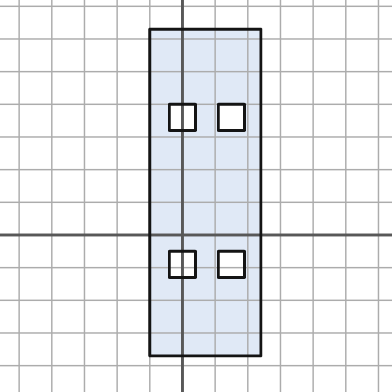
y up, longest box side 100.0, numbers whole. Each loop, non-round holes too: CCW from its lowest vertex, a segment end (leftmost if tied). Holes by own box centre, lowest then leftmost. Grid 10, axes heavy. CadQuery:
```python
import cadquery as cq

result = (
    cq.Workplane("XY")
    .moveTo(-10.0, -37.0)
    .lineTo(24.0, -37.0)
    .lineTo(24.0, 63.0)
    .lineTo(-10.0, 63.0)
    .close()
    .moveTo(-4.0, -13.0)
    .lineTo(4.0, -13.0)
    .lineTo(4.0, -5.0)
    .lineTo(-4.0, -5.0)
    .close()
    .moveTo(11.0, -13.0)
    .lineTo(19.0, -13.0)
    .lineTo(19.0, -5.0)
    .lineTo(11.0, -5.0)
    .close()
    .moveTo(-4.0, 32.0)
    .lineTo(4.0, 32.0)
    .lineTo(4.0, 40.0)
    .lineTo(-4.0, 40.0)
    .close()
    .moveTo(11.0, 32.0)
    .lineTo(19.0, 32.0)
    .lineTo(19.0, 40.0)
    .lineTo(11.0, 40.0)
    .close()
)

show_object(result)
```